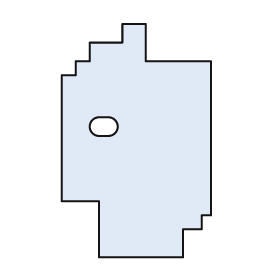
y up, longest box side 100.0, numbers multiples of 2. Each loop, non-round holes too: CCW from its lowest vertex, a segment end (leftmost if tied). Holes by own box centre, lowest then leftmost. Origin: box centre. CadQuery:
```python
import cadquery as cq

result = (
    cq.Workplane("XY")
    .moveTo(-16.0, -50.0)
    .lineTo(20.0, -50.0)
    .lineTo(20.0, -38.0)
    .lineTo(28.0, -38.0)
    .lineTo(28.0, -32.0)
    .lineTo(32.0, -32.0)
    .lineTo(32.0, 34.0)
    .lineTo(4.0, 34.0)
    .lineTo(4.0, 50.0)
    .lineTo(-6.0, 50.0)
    .lineTo(-6.0, 42.0)
    .lineTo(-20.0, 42.0)
    .lineTo(-20.0, 34.0)
    .lineTo(-26.0, 34.0)
    .lineTo(-26.0, 28.0)
    .lineTo(-32.0, 28.0)
    .lineTo(-32.0, -26.0)
    .lineTo(-16.0, -26.0)
    .close()
    .moveTo(-16.0, 2.0)
    .lineTo(-12.0, 2.0)
    .threePointArc((-8.0, 6.0), (-12.0, 10.0))
    .lineTo(-16.0, 10.0)
    .threePointArc((-20.0, 6.0), (-16.0, 2.0))
    .close()
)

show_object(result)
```